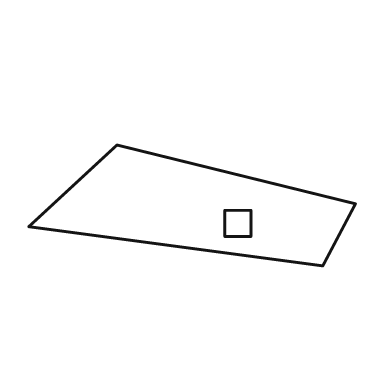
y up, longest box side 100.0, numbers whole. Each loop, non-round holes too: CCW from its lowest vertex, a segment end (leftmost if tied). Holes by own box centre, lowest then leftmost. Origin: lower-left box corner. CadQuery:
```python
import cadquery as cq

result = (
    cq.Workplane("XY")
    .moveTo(90.0, 0.0)
    .lineTo(100.0, 19.0)
    .lineTo(27.0, 37.0)
    .lineTo(0.0, 12.0)
    .close()
    .moveTo(60.0, 9.0)
    .lineTo(68.0, 9.0)
    .lineTo(68.0, 17.0)
    .lineTo(60.0, 17.0)
    .close()
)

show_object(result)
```